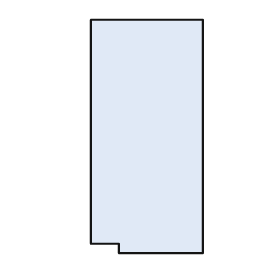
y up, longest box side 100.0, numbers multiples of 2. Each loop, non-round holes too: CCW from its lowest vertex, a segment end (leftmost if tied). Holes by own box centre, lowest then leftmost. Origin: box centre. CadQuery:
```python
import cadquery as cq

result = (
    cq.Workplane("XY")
    .moveTo(-12.0, -50.0)
    .lineTo(24.0, -50.0)
    .lineTo(24.0, 50.0)
    .lineTo(-24.0, 50.0)
    .lineTo(-24.0, -46.0)
    .lineTo(-12.0, -46.0)
    .close()
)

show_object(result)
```